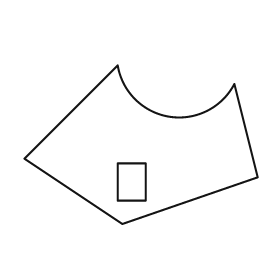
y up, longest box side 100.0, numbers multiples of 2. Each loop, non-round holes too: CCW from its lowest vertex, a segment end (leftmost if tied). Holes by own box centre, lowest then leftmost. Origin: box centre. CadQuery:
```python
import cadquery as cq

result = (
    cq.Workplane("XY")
    .moveTo(-8.0, -34.0)
    .lineTo(50.0, -14.0)
    .lineTo(40.0, 26.0)
    .threePointArc((12.0, 12.0), (-10.0, 34.0))
    .lineTo(-50.0, -6.0)
    .close()
    .moveTo(-10.0, -24.0)
    .lineTo(2.0, -24.0)
    .lineTo(2.0, -8.0)
    .lineTo(-10.0, -8.0)
    .close()
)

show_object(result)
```